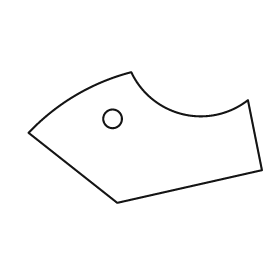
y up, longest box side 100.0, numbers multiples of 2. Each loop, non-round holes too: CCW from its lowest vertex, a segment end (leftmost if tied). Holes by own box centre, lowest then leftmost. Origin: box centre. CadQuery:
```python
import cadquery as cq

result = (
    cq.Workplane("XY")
    .moveTo(-12.0, -28.0)
    .lineTo(50.0, -14.0)
    .lineTo(44.0, 16.0)
    .threePointArc((16.0, 10.0), (-6.0, 28.0))
    .threePointArc((-30.0, 18.0), (-50.0, 2.0))
    .close()
    .moveTo(-14.0, 8.0)
    .circle(4.0)
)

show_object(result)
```